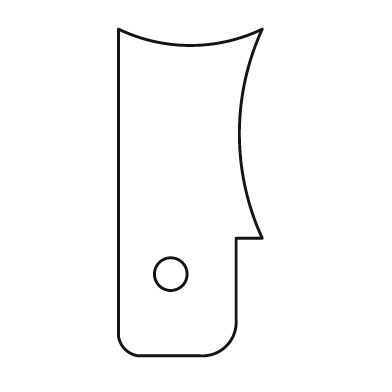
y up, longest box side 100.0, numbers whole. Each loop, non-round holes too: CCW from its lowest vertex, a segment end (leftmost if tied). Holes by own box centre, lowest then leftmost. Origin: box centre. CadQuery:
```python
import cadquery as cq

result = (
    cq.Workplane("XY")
    .moveTo(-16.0, -50.0)
    .lineTo(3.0, -50.0)
    .threePointArc((11.0, -47.0), (14.0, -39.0))
    .lineTo(14.0, -14.0)
    .lineTo(22.0, -14.0)
    .threePointArc((15.0, 18.0), (22.0, 50.0))
    .threePointArc((0.0, 45.0), (-22.0, 50.0))
    .lineTo(-22.0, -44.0)
    .threePointArc((-20.0, -48.0), (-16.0, -50.0))
    .close()
    .moveTo(-6.0, -25.0)
    .circle(5.0)
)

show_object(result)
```